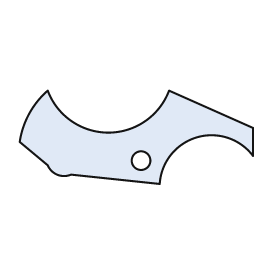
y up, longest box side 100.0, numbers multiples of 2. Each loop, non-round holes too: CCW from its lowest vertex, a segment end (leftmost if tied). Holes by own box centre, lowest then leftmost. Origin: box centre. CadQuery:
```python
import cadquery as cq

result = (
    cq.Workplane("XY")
    .moveTo(10.0, -20.0)
    .threePointArc((26.0, 0.0), (50.0, -8.0))
    .lineTo(50.0, 4.0)
    .lineTo(14.0, 20.0)
    .threePointArc((-12.0, 2.0), (-38.0, 20.0))
    .threePointArc((-46.0, 10.0), (-50.0, -2.0))
    .lineTo(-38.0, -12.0)
    .threePointArc((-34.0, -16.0), (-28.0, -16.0))
    .close()
    .moveTo(2.0, -10.0)
    .circle(4.0)
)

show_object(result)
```